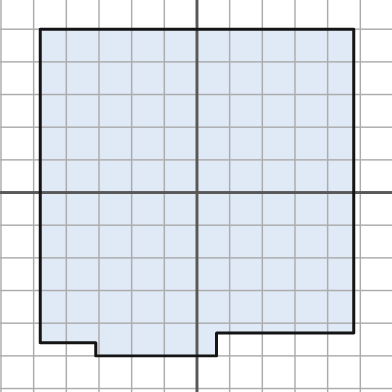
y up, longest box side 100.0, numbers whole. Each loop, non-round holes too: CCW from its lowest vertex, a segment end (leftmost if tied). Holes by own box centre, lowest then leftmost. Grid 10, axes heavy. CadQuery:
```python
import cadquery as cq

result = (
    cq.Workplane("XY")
    .moveTo(-31.0, -50.0)
    .lineTo(6.0, -50.0)
    .lineTo(6.0, -43.0)
    .lineTo(48.0, -43.0)
    .lineTo(48.0, 50.0)
    .lineTo(-48.0, 50.0)
    .lineTo(-48.0, -46.0)
    .lineTo(-31.0, -46.0)
    .close()
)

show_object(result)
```